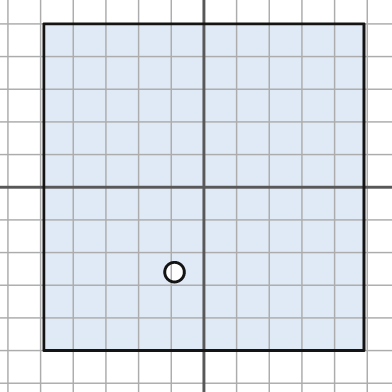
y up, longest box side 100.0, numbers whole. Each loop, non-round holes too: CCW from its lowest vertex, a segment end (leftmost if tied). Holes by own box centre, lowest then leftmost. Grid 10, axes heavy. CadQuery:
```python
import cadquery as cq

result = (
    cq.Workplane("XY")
    .moveTo(-49.0, -50.0)
    .lineTo(49.0, -50.0)
    .lineTo(49.0, 50.0)
    .lineTo(-49.0, 50.0)
    .close()
    .moveTo(-9.0, -26.0)
    .circle(3.0)
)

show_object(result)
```